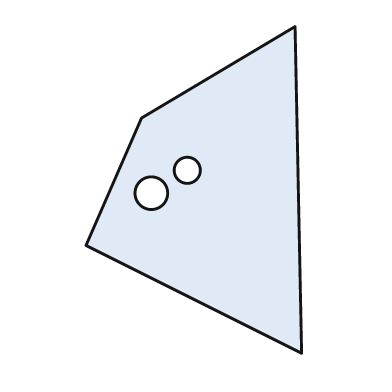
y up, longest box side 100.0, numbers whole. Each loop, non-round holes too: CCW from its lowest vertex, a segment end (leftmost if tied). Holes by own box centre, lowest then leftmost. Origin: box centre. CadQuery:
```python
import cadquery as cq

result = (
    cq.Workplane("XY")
    .moveTo(33.0, -50.0)
    .lineTo(31.0, 50.0)
    .lineTo(-16.0, 22.0)
    .lineTo(-33.0, -17.0)
    .close()
    .moveTo(-13.0, -1.0)
    .circle(5.0)
    .moveTo(-2.0, 6.0)
    .circle(4.0)
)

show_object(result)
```